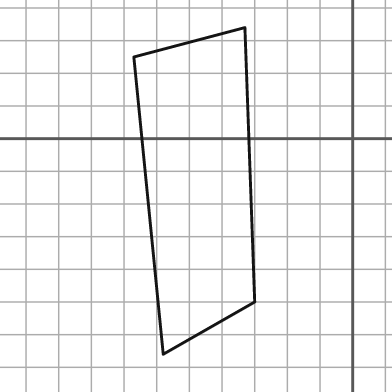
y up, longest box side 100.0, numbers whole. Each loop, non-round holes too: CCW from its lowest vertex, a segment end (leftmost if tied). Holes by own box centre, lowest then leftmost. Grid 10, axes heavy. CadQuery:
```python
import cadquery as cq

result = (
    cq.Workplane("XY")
    .moveTo(-58.0, -66.0)
    .lineTo(-30.0, -50.0)
    .lineTo(-33.0, 34.0)
    .lineTo(-67.0, 25.0)
    .close()
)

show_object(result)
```